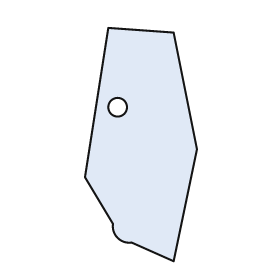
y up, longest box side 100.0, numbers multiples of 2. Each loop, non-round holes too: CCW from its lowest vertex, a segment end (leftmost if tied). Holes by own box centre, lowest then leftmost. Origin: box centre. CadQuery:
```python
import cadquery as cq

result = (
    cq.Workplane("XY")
    .moveTo(14.0, -50.0)
    .lineTo(24.0, -2.0)
    .lineTo(14.0, 48.0)
    .lineTo(-14.0, 50.0)
    .lineTo(-24.0, -14.0)
    .lineTo(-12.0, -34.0)
    .threePointArc((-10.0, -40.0), (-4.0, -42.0))
    .close()
    .moveTo(-10.0, 16.0)
    .circle(4.0)
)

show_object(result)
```